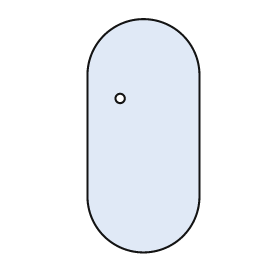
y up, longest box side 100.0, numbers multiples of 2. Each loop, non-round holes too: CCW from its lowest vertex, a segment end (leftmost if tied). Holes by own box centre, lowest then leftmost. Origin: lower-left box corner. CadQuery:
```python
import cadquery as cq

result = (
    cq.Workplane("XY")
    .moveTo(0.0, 24.0)
    .threePointArc((24.0, 0.0), (48.0, 24.0))
    .lineTo(48.0, 76.0)
    .threePointArc((24.0, 100.0), (0.0, 76.0))
    .close()
    .moveTo(14.0, 66.0)
    .circle(2.0)
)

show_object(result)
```